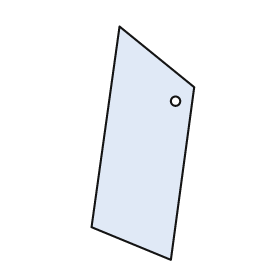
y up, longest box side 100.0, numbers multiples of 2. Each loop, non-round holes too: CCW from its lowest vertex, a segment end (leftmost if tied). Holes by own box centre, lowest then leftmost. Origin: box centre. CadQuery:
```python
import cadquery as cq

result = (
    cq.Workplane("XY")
    .moveTo(12.0, -50.0)
    .lineTo(22.0, 24.0)
    .lineTo(-10.0, 50.0)
    .lineTo(-22.0, -36.0)
    .close()
    .moveTo(14.0, 18.0)
    .circle(2.0)
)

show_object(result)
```